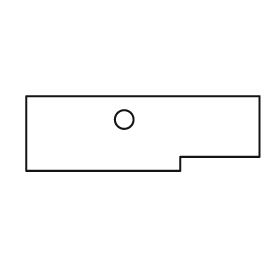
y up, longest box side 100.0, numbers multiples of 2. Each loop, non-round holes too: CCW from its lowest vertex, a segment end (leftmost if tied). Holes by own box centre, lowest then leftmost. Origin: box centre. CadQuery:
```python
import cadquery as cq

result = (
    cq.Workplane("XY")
    .moveTo(-50.0, -16.0)
    .lineTo(16.0, -16.0)
    .lineTo(16.0, -10.0)
    .lineTo(50.0, -10.0)
    .lineTo(50.0, 16.0)
    .lineTo(-50.0, 16.0)
    .close()
    .moveTo(-8.0, 6.0)
    .circle(4.0)
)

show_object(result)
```